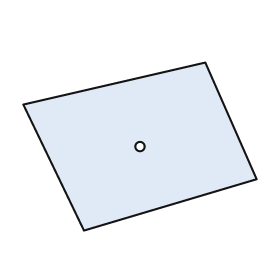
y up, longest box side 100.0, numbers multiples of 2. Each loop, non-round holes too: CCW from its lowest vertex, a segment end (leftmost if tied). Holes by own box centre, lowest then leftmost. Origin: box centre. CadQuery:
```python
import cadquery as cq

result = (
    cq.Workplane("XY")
    .moveTo(-24.0, -36.0)
    .lineTo(50.0, -14.0)
    .lineTo(28.0, 36.0)
    .lineTo(-50.0, 18.0)
    .close()
    .moveTo(0.0, 0.0)
    .circle(2.0)
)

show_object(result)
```